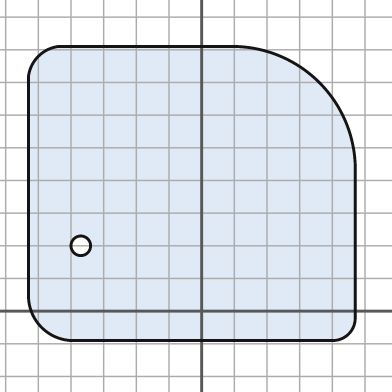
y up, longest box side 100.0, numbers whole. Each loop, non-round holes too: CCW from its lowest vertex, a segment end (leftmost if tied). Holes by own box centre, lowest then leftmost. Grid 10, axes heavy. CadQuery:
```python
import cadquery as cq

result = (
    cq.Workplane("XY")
    .moveTo(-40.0, -9.0)
    .lineTo(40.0, -9.0)
    .threePointArc((45.0, -7.0), (47.0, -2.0))
    .lineTo(47.0, 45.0)
    .threePointArc((36.0, 70.0), (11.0, 81.0))
    .lineTo(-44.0, 81.0)
    .threePointArc((-50.0, 78.0), (-53.0, 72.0))
    .lineTo(-53.0, 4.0)
    .threePointArc((-49.0, -5.0), (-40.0, -9.0))
    .close()
    .moveTo(-37.0, 20.0)
    .circle(3.0)
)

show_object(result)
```